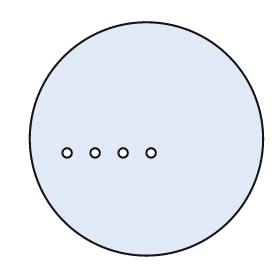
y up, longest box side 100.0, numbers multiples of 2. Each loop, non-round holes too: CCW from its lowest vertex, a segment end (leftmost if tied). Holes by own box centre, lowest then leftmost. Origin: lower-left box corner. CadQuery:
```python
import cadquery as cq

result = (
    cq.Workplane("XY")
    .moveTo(50.0, 50.0)
    .circle(50.0)
    .moveTo(16.0, 44.0)
    .circle(2.0)
    .moveTo(28.0, 44.0)
    .circle(2.0)
    .moveTo(40.0, 44.0)
    .circle(2.0)
    .moveTo(52.0, 44.0)
    .circle(2.0)
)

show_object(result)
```